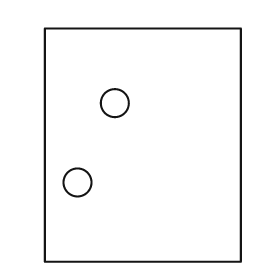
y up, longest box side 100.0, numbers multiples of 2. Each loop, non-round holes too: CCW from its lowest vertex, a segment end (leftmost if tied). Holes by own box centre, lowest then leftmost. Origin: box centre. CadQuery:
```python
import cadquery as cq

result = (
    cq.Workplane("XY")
    .moveTo(-42.0, -50.0)
    .lineTo(42.0, -50.0)
    .lineTo(42.0, 50.0)
    .lineTo(-42.0, 50.0)
    .close()
    .moveTo(-28.0, -16.0)
    .circle(6.0)
    .moveTo(-12.0, 18.0)
    .circle(6.0)
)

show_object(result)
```